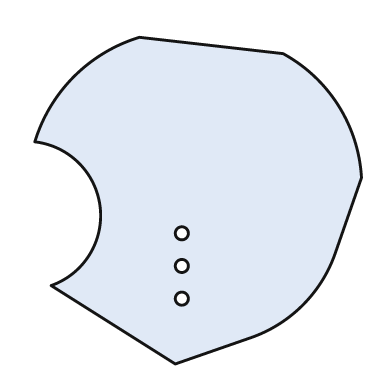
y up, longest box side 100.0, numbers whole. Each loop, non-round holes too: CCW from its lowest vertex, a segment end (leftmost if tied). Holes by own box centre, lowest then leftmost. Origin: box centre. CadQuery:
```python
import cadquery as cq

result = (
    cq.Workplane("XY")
    .moveTo(-7.0, -50.0)
    .lineTo(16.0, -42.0)
    .threePointArc((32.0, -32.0), (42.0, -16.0))
    .lineTo(50.0, 7.0)
    .threePointArc((43.0, 29.0), (26.0, 45.0))
    .lineTo(-18.0, 50.0)
    .threePointArc((-38.0, 38.0), (-50.0, 18.0))
    .threePointArc((-30.0, -2.0), (-45.0, -26.0))
    .close()
    .moveTo(-5.0, -30.0)
    .circle(2.0)
    .moveTo(-5.0, -20.0)
    .circle(2.0)
    .moveTo(-5.0, -10.0)
    .circle(2.0)
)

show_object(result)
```